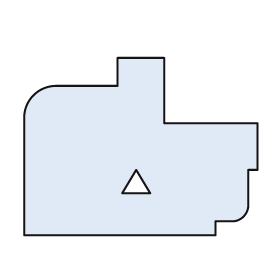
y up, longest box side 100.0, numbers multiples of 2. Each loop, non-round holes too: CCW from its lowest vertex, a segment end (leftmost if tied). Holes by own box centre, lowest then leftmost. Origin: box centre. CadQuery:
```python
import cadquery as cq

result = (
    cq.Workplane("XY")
    .moveTo(-50.0, -38.0)
    .lineTo(32.0, -38.0)
    .lineTo(32.0, -32.0)
    .lineTo(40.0, -32.0)
    .threePointArc((44.0, -30.0), (46.0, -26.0))
    .lineTo(46.0, -10.0)
    .lineTo(50.0, -10.0)
    .lineTo(50.0, 10.0)
    .lineTo(10.0, 10.0)
    .lineTo(10.0, 38.0)
    .lineTo(-10.0, 38.0)
    .lineTo(-10.0, 26.0)
    .lineTo(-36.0, 26.0)
    .threePointArc((-46.0, 22.0), (-50.0, 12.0))
    .close()
    .moveTo(-8.0, -20.0)
    .lineTo(4.0, -20.0)
    .lineTo(-2.0, -10.0)
    .close()
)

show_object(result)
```